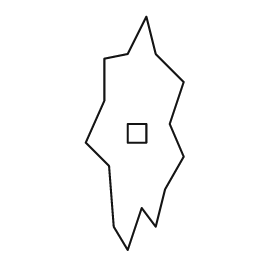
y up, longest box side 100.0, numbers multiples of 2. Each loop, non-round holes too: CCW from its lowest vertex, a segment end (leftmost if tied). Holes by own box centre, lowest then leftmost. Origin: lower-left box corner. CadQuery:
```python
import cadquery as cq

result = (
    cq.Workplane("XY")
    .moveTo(18.0, 0.0)
    .lineTo(24.0, 18.0)
    .lineTo(30.0, 10.0)
    .lineTo(34.0, 26.0)
    .lineTo(42.0, 40.0)
    .lineTo(36.0, 54.0)
    .lineTo(42.0, 72.0)
    .lineTo(30.0, 84.0)
    .lineTo(26.0, 100.0)
    .lineTo(18.0, 84.0)
    .lineTo(8.0, 82.0)
    .lineTo(8.0, 64.0)
    .lineTo(0.0, 46.0)
    .lineTo(10.0, 36.0)
    .lineTo(12.0, 10.0)
    .close()
    .moveTo(18.0, 46.0)
    .lineTo(26.0, 46.0)
    .lineTo(26.0, 54.0)
    .lineTo(18.0, 54.0)
    .close()
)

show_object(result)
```